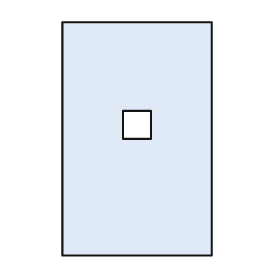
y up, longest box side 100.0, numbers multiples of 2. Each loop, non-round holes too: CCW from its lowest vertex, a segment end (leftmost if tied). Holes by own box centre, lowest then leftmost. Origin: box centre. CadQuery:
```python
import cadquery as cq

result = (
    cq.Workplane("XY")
    .moveTo(-32.0, -50.0)
    .lineTo(32.0, -50.0)
    .lineTo(32.0, 50.0)
    .lineTo(-32.0, 50.0)
    .close()
    .moveTo(-6.0, 0.0)
    .lineTo(6.0, 0.0)
    .lineTo(6.0, 12.0)
    .lineTo(-6.0, 12.0)
    .close()
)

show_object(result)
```